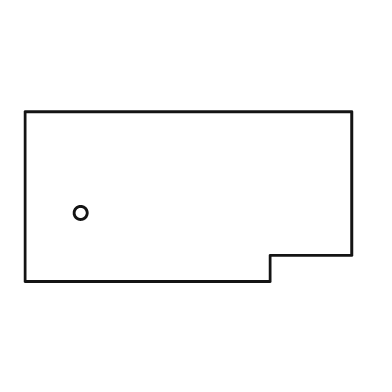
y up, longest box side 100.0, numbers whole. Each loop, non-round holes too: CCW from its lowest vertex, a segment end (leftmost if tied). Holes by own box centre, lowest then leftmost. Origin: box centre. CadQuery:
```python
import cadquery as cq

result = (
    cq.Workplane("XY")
    .moveTo(-50.0, -26.0)
    .lineTo(25.0, -26.0)
    .lineTo(25.0, -18.0)
    .lineTo(50.0, -18.0)
    .lineTo(50.0, 26.0)
    .lineTo(-50.0, 26.0)
    .close()
    .moveTo(-33.0, -5.0)
    .circle(2.0)
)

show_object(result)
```